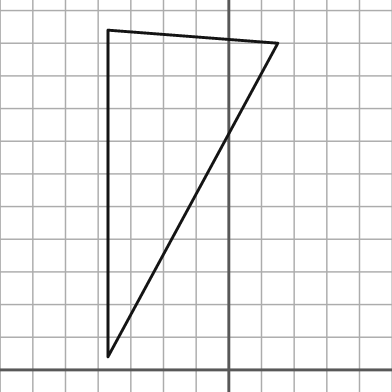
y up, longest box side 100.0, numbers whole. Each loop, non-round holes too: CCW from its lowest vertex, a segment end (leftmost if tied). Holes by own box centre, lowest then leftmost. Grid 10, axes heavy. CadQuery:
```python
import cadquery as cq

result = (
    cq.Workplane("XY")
    .moveTo(-37.0, 4.0)
    .lineTo(15.0, 100.0)
    .lineTo(-37.0, 104.0)
    .close()
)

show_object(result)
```